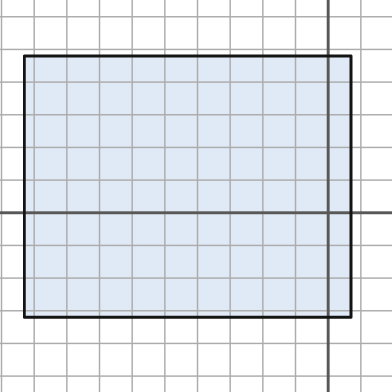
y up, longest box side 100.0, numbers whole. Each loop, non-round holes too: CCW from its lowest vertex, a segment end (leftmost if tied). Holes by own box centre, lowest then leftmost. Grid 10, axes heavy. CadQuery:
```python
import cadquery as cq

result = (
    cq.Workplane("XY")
    .moveTo(-93.0, -32.0)
    .lineTo(7.0, -32.0)
    .lineTo(7.0, 48.0)
    .lineTo(-93.0, 48.0)
    .close()
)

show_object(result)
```